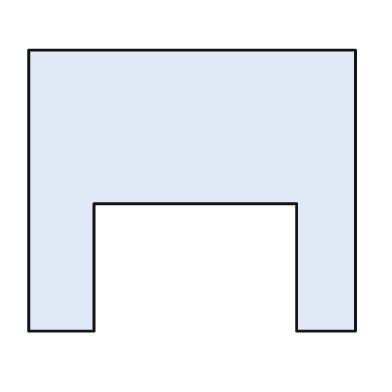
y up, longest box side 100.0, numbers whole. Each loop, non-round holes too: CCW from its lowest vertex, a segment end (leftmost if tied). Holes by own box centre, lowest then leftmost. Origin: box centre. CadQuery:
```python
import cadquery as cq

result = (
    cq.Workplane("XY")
    .moveTo(-50.0, -43.0)
    .lineTo(-30.0, -43.0)
    .lineTo(-30.0, -4.0)
    .lineTo(32.0, -4.0)
    .lineTo(32.0, -43.0)
    .lineTo(50.0, -43.0)
    .lineTo(50.0, 43.0)
    .lineTo(-50.0, 43.0)
    .close()
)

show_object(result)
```